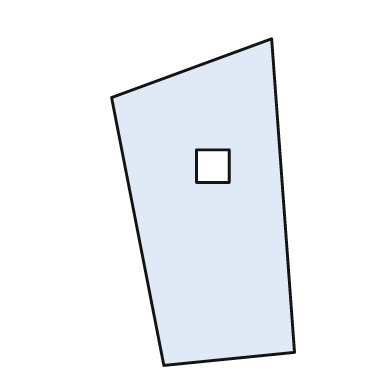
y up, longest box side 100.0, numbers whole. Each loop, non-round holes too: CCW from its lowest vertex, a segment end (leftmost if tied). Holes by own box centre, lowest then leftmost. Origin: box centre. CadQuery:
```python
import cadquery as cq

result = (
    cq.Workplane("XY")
    .moveTo(-12.0, -50.0)
    .lineTo(28.0, -46.0)
    .lineTo(21.0, 50.0)
    .lineTo(-28.0, 32.0)
    .close()
    .moveTo(-2.0, 6.0)
    .lineTo(8.0, 6.0)
    .lineTo(8.0, 16.0)
    .lineTo(-2.0, 16.0)
    .close()
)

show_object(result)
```